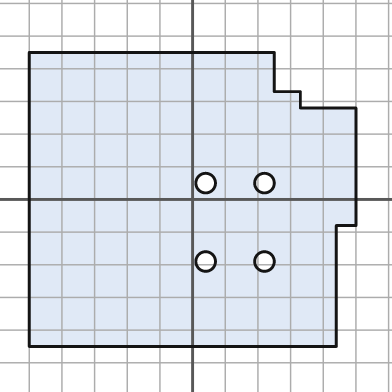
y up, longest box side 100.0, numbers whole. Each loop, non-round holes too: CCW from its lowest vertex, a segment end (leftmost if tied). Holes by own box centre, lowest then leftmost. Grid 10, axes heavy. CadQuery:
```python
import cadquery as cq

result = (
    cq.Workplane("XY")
    .moveTo(-50.0, -45.0)
    .lineTo(44.0, -45.0)
    .lineTo(44.0, -8.0)
    .lineTo(50.0, -8.0)
    .lineTo(50.0, 28.0)
    .lineTo(33.0, 28.0)
    .lineTo(33.0, 33.0)
    .lineTo(25.0, 33.0)
    .lineTo(25.0, 45.0)
    .lineTo(-50.0, 45.0)
    .close()
    .moveTo(4.0, -19.0)
    .circle(3.0)
    .moveTo(22.0, -19.0)
    .circle(3.0)
    .moveTo(4.0, 5.0)
    .circle(3.0)
    .moveTo(22.0, 5.0)
    .circle(3.0)
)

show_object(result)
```